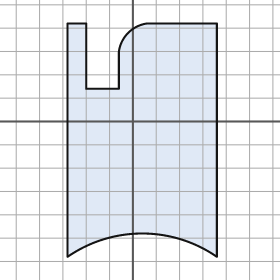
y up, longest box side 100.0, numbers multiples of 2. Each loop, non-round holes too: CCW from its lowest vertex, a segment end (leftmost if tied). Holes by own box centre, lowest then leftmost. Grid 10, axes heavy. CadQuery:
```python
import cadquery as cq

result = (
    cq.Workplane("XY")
    .moveTo(-28.0, -58.0)
    .threePointArc((4.0, -48.0), (36.0, -58.0))
    .lineTo(36.0, 42.0)
    .lineTo(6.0, 42.0)
    .threePointArc((-2.0, 38.0), (-6.0, 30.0))
    .lineTo(-6.0, 14.0)
    .lineTo(-20.0, 14.0)
    .lineTo(-20.0, 42.0)
    .lineTo(-28.0, 42.0)
    .close()
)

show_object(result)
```